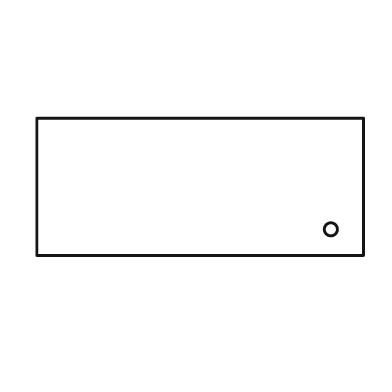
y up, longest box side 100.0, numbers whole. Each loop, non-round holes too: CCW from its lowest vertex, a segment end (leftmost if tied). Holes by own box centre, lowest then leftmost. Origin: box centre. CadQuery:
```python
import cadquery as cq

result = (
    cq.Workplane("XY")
    .moveTo(-50.0, -21.0)
    .lineTo(50.0, -21.0)
    .lineTo(50.0, 21.0)
    .lineTo(-50.0, 21.0)
    .close()
    .moveTo(40.0, -13.0)
    .circle(2.0)
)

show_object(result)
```